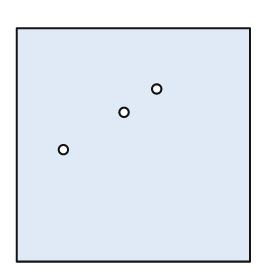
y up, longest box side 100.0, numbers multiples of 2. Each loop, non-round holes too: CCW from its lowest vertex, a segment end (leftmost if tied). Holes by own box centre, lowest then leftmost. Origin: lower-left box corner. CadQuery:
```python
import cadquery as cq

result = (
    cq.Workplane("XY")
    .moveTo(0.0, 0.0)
    .lineTo(100.0, 0.0)
    .lineTo(100.0, 100.0)
    .lineTo(0.0, 100.0)
    .close()
    .moveTo(20.0, 48.0)
    .circle(2.0)
    .moveTo(46.0, 64.0)
    .circle(2.0)
    .moveTo(60.0, 74.0)
    .circle(2.0)
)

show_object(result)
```